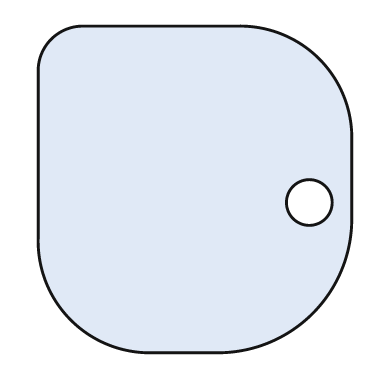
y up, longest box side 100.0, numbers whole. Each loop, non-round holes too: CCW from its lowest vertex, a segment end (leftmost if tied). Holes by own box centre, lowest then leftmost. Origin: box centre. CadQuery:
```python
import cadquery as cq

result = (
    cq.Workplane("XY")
    .moveTo(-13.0, -50.0)
    .lineTo(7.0, -50.0)
    .threePointArc((36.0, -38.0), (48.0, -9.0))
    .lineTo(48.0, 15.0)
    .threePointArc((38.0, 40.0), (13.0, 50.0))
    .lineTo(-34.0, 50.0)
    .threePointArc((-44.0, 46.0), (-48.0, 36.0))
    .lineTo(-48.0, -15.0)
    .threePointArc((-38.0, -40.0), (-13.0, -50.0))
    .close()
    .moveTo(35.0, -4.0)
    .circle(7.0)
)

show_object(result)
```